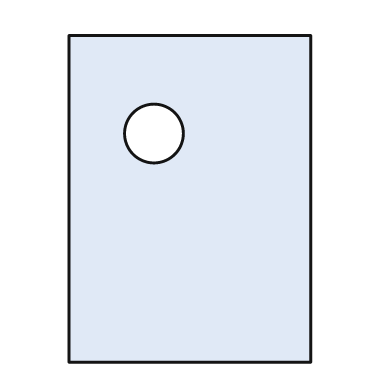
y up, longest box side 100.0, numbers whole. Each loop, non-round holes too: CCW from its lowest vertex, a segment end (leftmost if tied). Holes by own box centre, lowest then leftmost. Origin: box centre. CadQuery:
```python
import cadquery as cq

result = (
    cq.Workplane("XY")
    .moveTo(-37.0, -50.0)
    .lineTo(37.0, -50.0)
    .lineTo(37.0, 50.0)
    .lineTo(-37.0, 50.0)
    .close()
    .moveTo(-11.0, 20.0)
    .circle(9.0)
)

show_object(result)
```